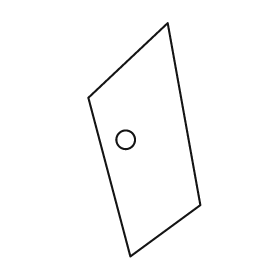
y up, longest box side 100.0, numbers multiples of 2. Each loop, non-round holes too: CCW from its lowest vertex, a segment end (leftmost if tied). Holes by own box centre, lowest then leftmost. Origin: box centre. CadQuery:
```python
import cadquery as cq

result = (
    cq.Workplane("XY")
    .moveTo(-6.0, -50.0)
    .lineTo(24.0, -28.0)
    .lineTo(10.0, 50.0)
    .lineTo(-24.0, 18.0)
    .close()
    .moveTo(-8.0, 0.0)
    .circle(4.0)
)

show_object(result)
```